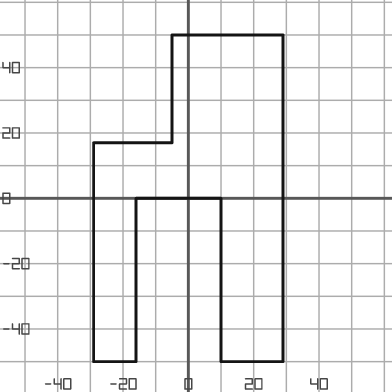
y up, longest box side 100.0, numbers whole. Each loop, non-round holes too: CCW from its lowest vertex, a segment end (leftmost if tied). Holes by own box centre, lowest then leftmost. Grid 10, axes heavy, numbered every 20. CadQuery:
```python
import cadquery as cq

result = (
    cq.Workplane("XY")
    .moveTo(-29.0, -50.0)
    .lineTo(-16.0, -50.0)
    .lineTo(-16.0, 0.0)
    .lineTo(10.0, 0.0)
    .lineTo(10.0, -50.0)
    .lineTo(29.0, -50.0)
    .lineTo(29.0, 50.0)
    .lineTo(-5.0, 50.0)
    .lineTo(-5.0, 17.0)
    .lineTo(-29.0, 17.0)
    .close()
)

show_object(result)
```